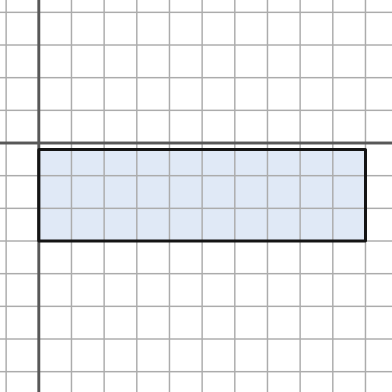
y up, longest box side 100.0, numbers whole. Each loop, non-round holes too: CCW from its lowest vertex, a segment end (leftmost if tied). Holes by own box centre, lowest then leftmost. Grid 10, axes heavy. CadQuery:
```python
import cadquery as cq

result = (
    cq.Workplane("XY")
    .moveTo(0.0, -30.0)
    .lineTo(100.0, -30.0)
    .lineTo(100.0, -2.0)
    .lineTo(0.0, -2.0)
    .close()
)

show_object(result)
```